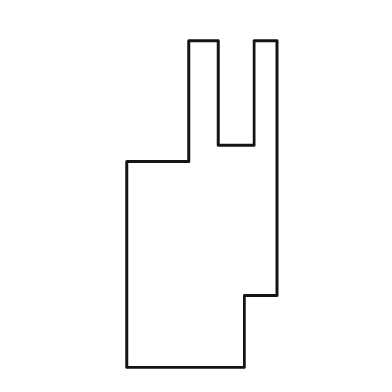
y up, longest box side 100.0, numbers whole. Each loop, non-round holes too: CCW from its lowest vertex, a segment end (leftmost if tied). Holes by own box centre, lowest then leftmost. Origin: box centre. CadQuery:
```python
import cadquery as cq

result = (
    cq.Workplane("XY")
    .moveTo(-23.0, -50.0)
    .lineTo(13.0, -50.0)
    .lineTo(13.0, -28.0)
    .lineTo(23.0, -28.0)
    .lineTo(23.0, 50.0)
    .lineTo(16.0, 50.0)
    .lineTo(16.0, 18.0)
    .lineTo(5.0, 18.0)
    .lineTo(5.0, 50.0)
    .lineTo(-4.0, 50.0)
    .lineTo(-4.0, 13.0)
    .lineTo(-23.0, 13.0)
    .close()
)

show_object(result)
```